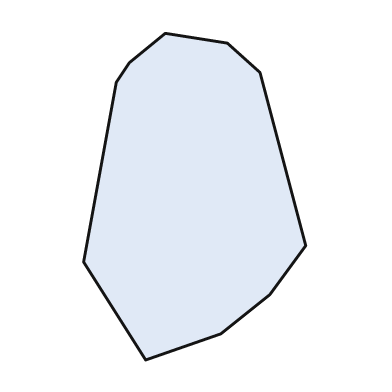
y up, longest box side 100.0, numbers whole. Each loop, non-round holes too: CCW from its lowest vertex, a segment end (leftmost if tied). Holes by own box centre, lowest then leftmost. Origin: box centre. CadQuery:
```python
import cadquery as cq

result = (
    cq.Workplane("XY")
    .moveTo(-15.0, -50.0)
    .lineTo(8.0, -42.0)
    .lineTo(23.0, -30.0)
    .lineTo(34.0, -15.0)
    .lineTo(20.0, 38.0)
    .lineTo(10.0, 47.0)
    .lineTo(-9.0, 50.0)
    .lineTo(-20.0, 41.0)
    .lineTo(-24.0, 35.0)
    .lineTo(-34.0, -20.0)
    .close()
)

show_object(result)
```